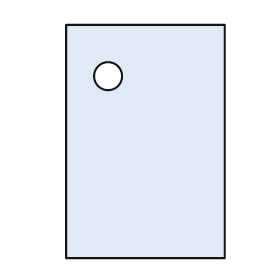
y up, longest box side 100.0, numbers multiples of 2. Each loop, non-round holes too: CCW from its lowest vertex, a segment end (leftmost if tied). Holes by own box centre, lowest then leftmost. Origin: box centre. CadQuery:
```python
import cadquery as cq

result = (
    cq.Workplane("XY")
    .moveTo(-34.0, -50.0)
    .lineTo(34.0, -50.0)
    .lineTo(34.0, 50.0)
    .lineTo(-34.0, 50.0)
    .close()
    .moveTo(-16.0, 28.0)
    .circle(6.0)
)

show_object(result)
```